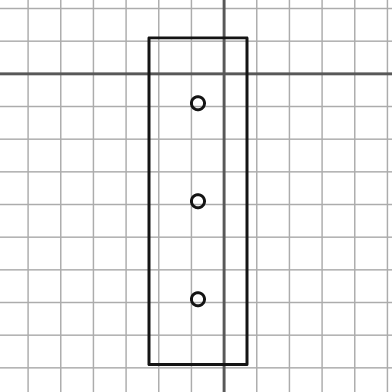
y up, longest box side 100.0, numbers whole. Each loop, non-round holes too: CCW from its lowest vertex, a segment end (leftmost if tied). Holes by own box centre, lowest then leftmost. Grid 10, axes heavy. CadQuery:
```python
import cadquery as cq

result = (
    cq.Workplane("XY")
    .moveTo(-23.0, -89.0)
    .lineTo(7.0, -89.0)
    .lineTo(7.0, 11.0)
    .lineTo(-23.0, 11.0)
    .close()
    .moveTo(-8.0, -69.0)
    .circle(2.0)
    .moveTo(-8.0, -39.0)
    .circle(2.0)
    .moveTo(-8.0, -9.0)
    .circle(2.0)
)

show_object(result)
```